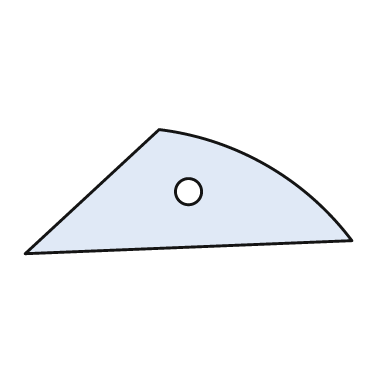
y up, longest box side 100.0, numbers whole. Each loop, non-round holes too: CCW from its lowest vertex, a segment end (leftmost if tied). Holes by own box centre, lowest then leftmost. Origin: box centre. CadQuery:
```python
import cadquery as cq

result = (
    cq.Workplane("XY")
    .moveTo(-50.0, -19.0)
    .lineTo(50.0, -15.0)
    .threePointArc((24.0, 8.0), (-9.0, 19.0))
    .close()
    .moveTo(0.0, 0.0)
    .circle(4.0)
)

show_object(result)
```